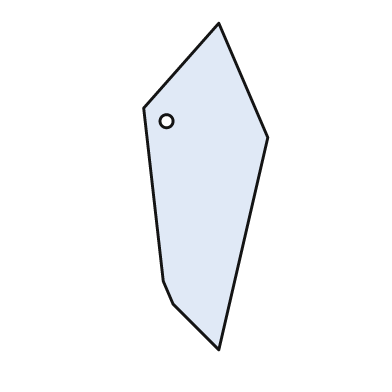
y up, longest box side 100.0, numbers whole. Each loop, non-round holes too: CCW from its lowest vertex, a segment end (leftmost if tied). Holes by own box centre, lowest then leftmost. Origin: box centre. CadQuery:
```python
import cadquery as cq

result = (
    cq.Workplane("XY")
    .moveTo(4.0, -50.0)
    .lineTo(19.0, 15.0)
    .lineTo(4.0, 50.0)
    .lineTo(-19.0, 24.0)
    .lineTo(-13.0, -29.0)
    .lineTo(-10.0, -36.0)
    .close()
    .moveTo(-12.0, 20.0)
    .circle(2.0)
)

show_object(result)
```